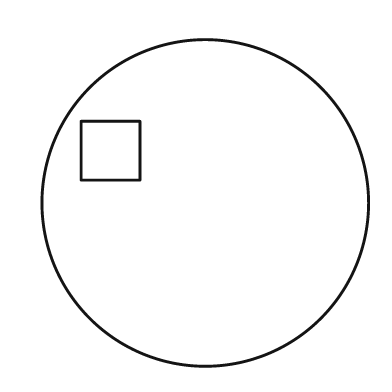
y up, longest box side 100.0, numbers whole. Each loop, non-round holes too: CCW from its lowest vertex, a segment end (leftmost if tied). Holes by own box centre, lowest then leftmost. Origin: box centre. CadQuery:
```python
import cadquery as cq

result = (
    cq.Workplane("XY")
    .moveTo(0.0, 0.0)
    .circle(50.0)
    .moveTo(-38.0, 7.0)
    .lineTo(-20.0, 7.0)
    .lineTo(-20.0, 25.0)
    .lineTo(-38.0, 25.0)
    .close()
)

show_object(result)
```